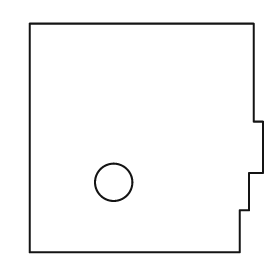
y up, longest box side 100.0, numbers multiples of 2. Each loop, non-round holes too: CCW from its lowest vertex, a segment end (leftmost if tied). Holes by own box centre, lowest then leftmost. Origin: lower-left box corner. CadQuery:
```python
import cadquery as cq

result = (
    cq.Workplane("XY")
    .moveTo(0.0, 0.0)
    .lineTo(90.0, 0.0)
    .lineTo(90.0, 18.0)
    .lineTo(94.0, 18.0)
    .lineTo(94.0, 34.0)
    .lineTo(100.0, 34.0)
    .lineTo(100.0, 56.0)
    .lineTo(96.0, 56.0)
    .lineTo(96.0, 98.0)
    .lineTo(0.0, 98.0)
    .close()
    .moveTo(36.0, 30.0)
    .circle(8.0)
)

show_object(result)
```